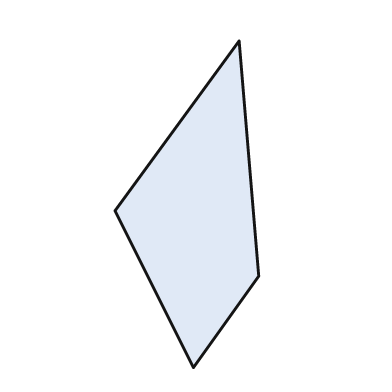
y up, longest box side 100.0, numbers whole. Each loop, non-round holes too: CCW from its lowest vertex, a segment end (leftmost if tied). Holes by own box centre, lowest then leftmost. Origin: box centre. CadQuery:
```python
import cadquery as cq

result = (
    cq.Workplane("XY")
    .moveTo(2.0, -50.0)
    .lineTo(22.0, -22.0)
    .lineTo(16.0, 50.0)
    .lineTo(-22.0, -2.0)
    .close()
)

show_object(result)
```